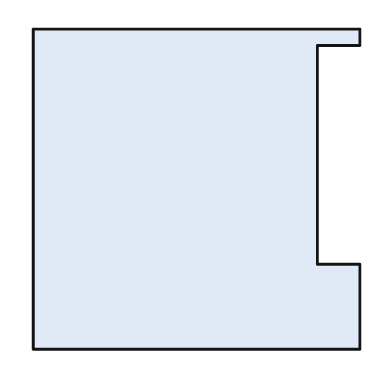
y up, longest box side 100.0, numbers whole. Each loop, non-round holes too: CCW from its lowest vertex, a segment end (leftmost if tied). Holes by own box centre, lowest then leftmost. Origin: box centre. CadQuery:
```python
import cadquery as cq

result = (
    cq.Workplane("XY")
    .moveTo(-50.0, -49.0)
    .lineTo(50.0, -49.0)
    .lineTo(50.0, -23.0)
    .lineTo(37.0, -23.0)
    .lineTo(37.0, 44.0)
    .lineTo(50.0, 44.0)
    .lineTo(50.0, 49.0)
    .lineTo(-50.0, 49.0)
    .close()
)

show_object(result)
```